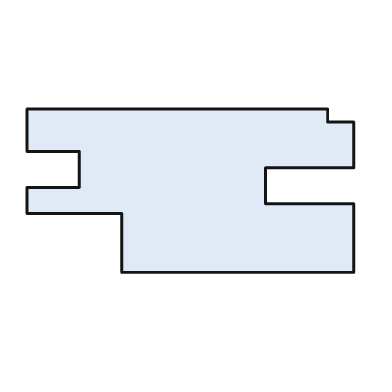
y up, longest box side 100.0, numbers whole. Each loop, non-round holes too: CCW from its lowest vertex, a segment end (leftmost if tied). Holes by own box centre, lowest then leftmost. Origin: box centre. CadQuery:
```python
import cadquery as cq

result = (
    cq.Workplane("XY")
    .moveTo(-21.0, -25.0)
    .lineTo(50.0, -25.0)
    .lineTo(50.0, -4.0)
    .lineTo(23.0, -4.0)
    .lineTo(23.0, 7.0)
    .lineTo(50.0, 7.0)
    .lineTo(50.0, 21.0)
    .lineTo(42.0, 21.0)
    .lineTo(42.0, 25.0)
    .lineTo(-50.0, 25.0)
    .lineTo(-50.0, 12.0)
    .lineTo(-34.0, 12.0)
    .lineTo(-34.0, 1.0)
    .lineTo(-50.0, 1.0)
    .lineTo(-50.0, -7.0)
    .lineTo(-21.0, -7.0)
    .close()
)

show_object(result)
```